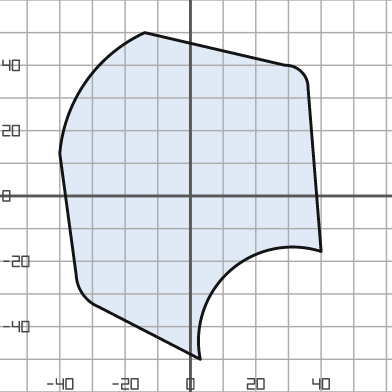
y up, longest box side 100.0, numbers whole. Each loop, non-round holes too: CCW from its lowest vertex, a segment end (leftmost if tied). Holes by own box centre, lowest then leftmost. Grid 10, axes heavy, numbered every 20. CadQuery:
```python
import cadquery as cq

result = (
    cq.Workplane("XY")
    .moveTo(3.0, -50.0)
    .threePointArc((12.0, -23.0), (40.0, -17.0))
    .lineTo(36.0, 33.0)
    .threePointArc((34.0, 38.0), (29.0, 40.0))
    .lineTo(-14.0, 50.0)
    .threePointArc((-32.0, 35.0), (-40.0, 13.0))
    .lineTo(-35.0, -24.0)
    .threePointArc((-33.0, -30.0), (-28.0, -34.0))
    .close()
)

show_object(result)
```